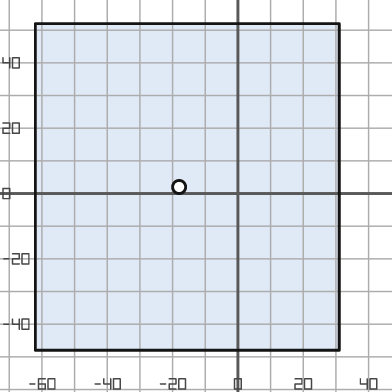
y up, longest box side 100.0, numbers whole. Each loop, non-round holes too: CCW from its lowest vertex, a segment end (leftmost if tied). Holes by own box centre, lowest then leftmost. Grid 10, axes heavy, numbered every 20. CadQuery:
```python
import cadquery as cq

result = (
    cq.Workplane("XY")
    .moveTo(-62.0, -48.0)
    .lineTo(31.0, -48.0)
    .lineTo(31.0, 52.0)
    .lineTo(-62.0, 52.0)
    .close()
    .moveTo(-18.0, 2.0)
    .circle(2.0)
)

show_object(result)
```